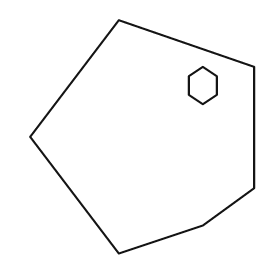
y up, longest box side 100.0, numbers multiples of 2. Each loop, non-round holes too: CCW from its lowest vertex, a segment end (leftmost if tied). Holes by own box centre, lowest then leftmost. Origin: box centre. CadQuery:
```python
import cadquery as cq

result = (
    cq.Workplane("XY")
    .moveTo(-10.0, -50.0)
    .lineTo(26.0, -38.0)
    .lineTo(48.0, -22.0)
    .lineTo(48.0, 30.0)
    .lineTo(-10.0, 50.0)
    .lineTo(-48.0, 0.0)
    .close()
    .moveTo(26.0, 14.0)
    .lineTo(32.0, 18.0)
    .lineTo(32.0, 26.0)
    .lineTo(26.0, 30.0)
    .lineTo(20.0, 26.0)
    .lineTo(20.0, 18.0)
    .close()
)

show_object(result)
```